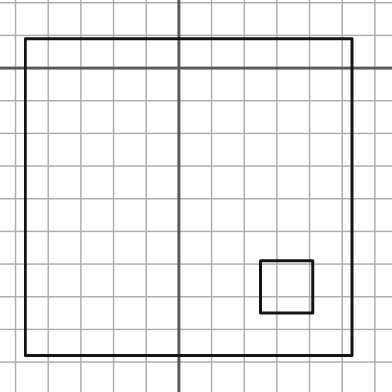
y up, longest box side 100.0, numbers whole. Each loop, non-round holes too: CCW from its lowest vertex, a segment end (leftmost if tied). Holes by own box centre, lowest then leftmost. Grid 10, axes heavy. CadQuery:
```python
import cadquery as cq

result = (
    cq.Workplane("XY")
    .moveTo(-47.0, -88.0)
    .lineTo(53.0, -88.0)
    .lineTo(53.0, 9.0)
    .lineTo(-47.0, 9.0)
    .close()
    .moveTo(25.0, -75.0)
    .lineTo(41.0, -75.0)
    .lineTo(41.0, -59.0)
    .lineTo(25.0, -59.0)
    .close()
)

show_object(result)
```